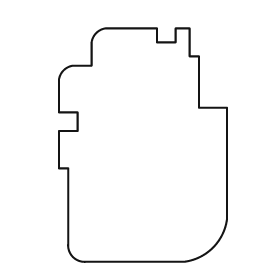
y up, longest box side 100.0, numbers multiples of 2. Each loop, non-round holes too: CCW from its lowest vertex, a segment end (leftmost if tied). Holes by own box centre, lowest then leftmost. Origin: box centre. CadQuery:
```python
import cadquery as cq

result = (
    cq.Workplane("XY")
    .moveTo(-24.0, -50.0)
    .lineTo(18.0, -50.0)
    .threePointArc((30.0, -44.0), (36.0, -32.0))
    .lineTo(36.0, 16.0)
    .lineTo(24.0, 16.0)
    .lineTo(24.0, 38.0)
    .lineTo(20.0, 38.0)
    .lineTo(20.0, 50.0)
    .lineTo(14.0, 50.0)
    .lineTo(14.0, 44.0)
    .lineTo(6.0, 44.0)
    .lineTo(6.0, 50.0)
    .lineTo(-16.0, 50.0)
    .threePointArc((-20.0, 48.0), (-22.0, 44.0))
    .lineTo(-22.0, 34.0)
    .lineTo(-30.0, 34.0)
    .threePointArc((-34.0, 32.0), (-36.0, 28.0))
    .lineTo(-36.0, 14.0)
    .lineTo(-28.0, 14.0)
    .lineTo(-28.0, 6.0)
    .lineTo(-36.0, 6.0)
    .lineTo(-36.0, -10.0)
    .lineTo(-32.0, -10.0)
    .lineTo(-32.0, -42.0)
    .threePointArc((-30.0, -48.0), (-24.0, -50.0))
    .close()
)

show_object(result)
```